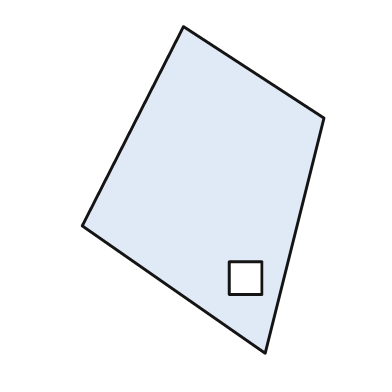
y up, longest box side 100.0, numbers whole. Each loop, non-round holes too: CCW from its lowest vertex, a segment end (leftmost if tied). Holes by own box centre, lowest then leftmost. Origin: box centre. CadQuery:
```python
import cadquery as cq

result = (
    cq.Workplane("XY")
    .moveTo(19.0, -50.0)
    .lineTo(37.0, 22.0)
    .lineTo(-6.0, 50.0)
    .lineTo(-37.0, -11.0)
    .close()
    .moveTo(8.0, -32.0)
    .lineTo(18.0, -32.0)
    .lineTo(18.0, -22.0)
    .lineTo(8.0, -22.0)
    .close()
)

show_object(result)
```